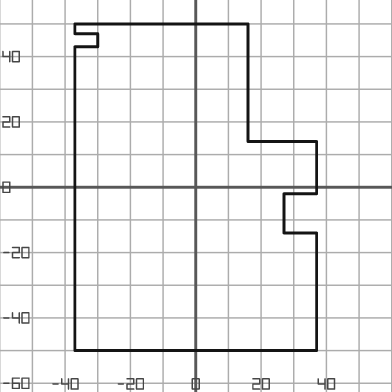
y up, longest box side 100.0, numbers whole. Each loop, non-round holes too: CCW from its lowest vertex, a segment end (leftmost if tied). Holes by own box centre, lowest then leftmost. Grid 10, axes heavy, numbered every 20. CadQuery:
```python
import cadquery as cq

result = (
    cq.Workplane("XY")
    .moveTo(-37.0, -50.0)
    .lineTo(37.0, -50.0)
    .lineTo(37.0, -14.0)
    .lineTo(27.0, -14.0)
    .lineTo(27.0, -2.0)
    .lineTo(37.0, -2.0)
    .lineTo(37.0, 14.0)
    .lineTo(16.0, 14.0)
    .lineTo(16.0, 50.0)
    .lineTo(-37.0, 50.0)
    .lineTo(-37.0, 47.0)
    .lineTo(-30.0, 47.0)
    .lineTo(-30.0, 43.0)
    .lineTo(-37.0, 43.0)
    .close()
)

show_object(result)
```